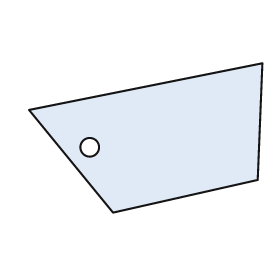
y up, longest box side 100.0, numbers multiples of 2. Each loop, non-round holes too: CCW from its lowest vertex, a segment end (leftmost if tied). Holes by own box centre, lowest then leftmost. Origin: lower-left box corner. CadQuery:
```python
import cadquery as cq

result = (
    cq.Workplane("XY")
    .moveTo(36.0, 0.0)
    .lineTo(98.0, 14.0)
    .lineTo(100.0, 64.0)
    .lineTo(0.0, 44.0)
    .close()
    .moveTo(26.0, 28.0)
    .circle(4.0)
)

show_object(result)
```